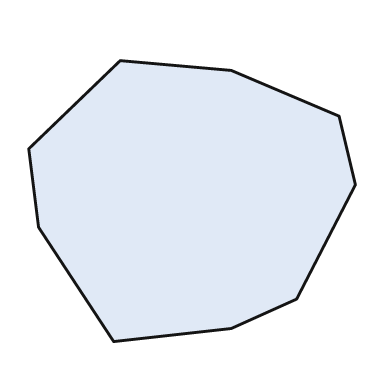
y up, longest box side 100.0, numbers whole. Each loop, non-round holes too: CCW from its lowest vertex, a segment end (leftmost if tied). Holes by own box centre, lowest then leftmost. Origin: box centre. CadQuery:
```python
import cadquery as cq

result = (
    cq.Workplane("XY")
    .moveTo(-24.0, -43.0)
    .lineTo(12.0, -39.0)
    .lineTo(32.0, -30.0)
    .lineTo(50.0, 5.0)
    .lineTo(45.0, 26.0)
    .lineTo(12.0, 40.0)
    .lineTo(-22.0, 43.0)
    .lineTo(-50.0, 16.0)
    .lineTo(-47.0, -8.0)
    .close()
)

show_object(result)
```